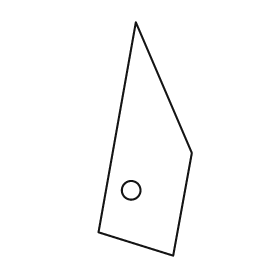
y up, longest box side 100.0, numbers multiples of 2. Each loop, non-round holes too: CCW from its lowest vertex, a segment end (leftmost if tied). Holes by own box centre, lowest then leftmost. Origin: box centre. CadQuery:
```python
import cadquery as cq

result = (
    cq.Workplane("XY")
    .moveTo(12.0, -50.0)
    .lineTo(20.0, -6.0)
    .lineTo(-4.0, 50.0)
    .lineTo(-20.0, -40.0)
    .close()
    .moveTo(-6.0, -22.0)
    .circle(4.0)
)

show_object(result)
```